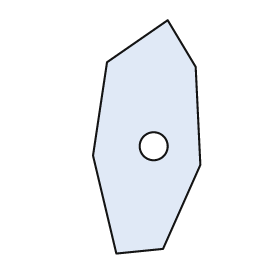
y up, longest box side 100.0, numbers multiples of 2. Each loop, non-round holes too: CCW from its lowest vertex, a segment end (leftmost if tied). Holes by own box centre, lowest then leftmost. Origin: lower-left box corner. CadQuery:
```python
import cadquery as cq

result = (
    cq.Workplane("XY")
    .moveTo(10.0, 0.0)
    .lineTo(30.0, 2.0)
    .lineTo(46.0, 38.0)
    .lineTo(44.0, 80.0)
    .lineTo(32.0, 100.0)
    .lineTo(6.0, 82.0)
    .lineTo(0.0, 42.0)
    .close()
    .moveTo(26.0, 46.0)
    .circle(6.0)
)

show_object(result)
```